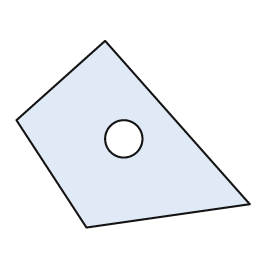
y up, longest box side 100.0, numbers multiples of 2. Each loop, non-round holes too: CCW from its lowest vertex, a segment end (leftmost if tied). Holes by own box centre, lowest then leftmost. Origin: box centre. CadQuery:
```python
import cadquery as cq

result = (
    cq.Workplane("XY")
    .moveTo(-20.0, -40.0)
    .lineTo(50.0, -30.0)
    .lineTo(-12.0, 40.0)
    .lineTo(-50.0, 6.0)
    .close()
    .moveTo(-4.0, -2.0)
    .circle(8.0)
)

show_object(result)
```